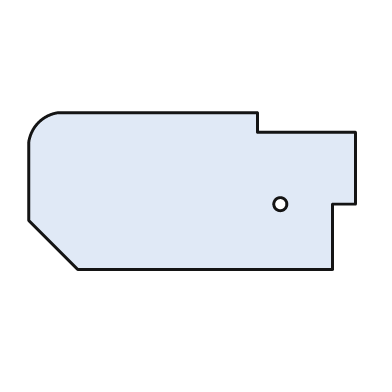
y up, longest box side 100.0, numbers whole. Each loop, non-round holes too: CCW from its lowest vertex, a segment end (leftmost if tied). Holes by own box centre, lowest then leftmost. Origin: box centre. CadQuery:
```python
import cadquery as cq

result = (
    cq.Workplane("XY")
    .moveTo(-35.0, -24.0)
    .lineTo(43.0, -24.0)
    .lineTo(43.0, -4.0)
    .lineTo(50.0, -4.0)
    .lineTo(50.0, 18.0)
    .lineTo(20.0, 18.0)
    .lineTo(20.0, 24.0)
    .lineTo(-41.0, 24.0)
    .threePointArc((-47.0, 21.0), (-50.0, 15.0))
    .lineTo(-50.0, -9.0)
    .close()
    .moveTo(27.0, -4.0)
    .circle(2.0)
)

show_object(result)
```